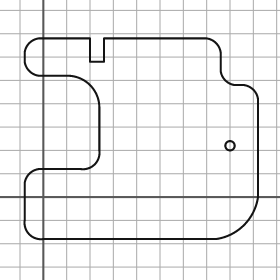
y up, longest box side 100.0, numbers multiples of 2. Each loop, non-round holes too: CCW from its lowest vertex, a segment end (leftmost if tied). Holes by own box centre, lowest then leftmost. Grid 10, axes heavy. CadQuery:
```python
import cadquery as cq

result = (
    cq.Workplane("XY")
    .moveTo(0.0, -18.0)
    .lineTo(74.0, -18.0)
    .threePointArc((86.0, -12.0), (92.0, 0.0))
    .lineTo(92.0, 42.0)
    .threePointArc((90.0, 46.0), (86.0, 48.0))
    .lineTo(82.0, 48.0)
    .threePointArc((78.0, 50.0), (76.0, 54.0))
    .lineTo(76.0, 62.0)
    .threePointArc((74.0, 66.0), (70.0, 68.0))
    .lineTo(26.0, 68.0)
    .lineTo(26.0, 58.0)
    .lineTo(20.0, 58.0)
    .lineTo(20.0, 68.0)
    .lineTo(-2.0, 68.0)
    .threePointArc((-6.0, 66.0), (-8.0, 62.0))
    .lineTo(-8.0, 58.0)
    .threePointArc((-6.0, 54.0), (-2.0, 52.0))
    .lineTo(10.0, 52.0)
    .threePointArc((20.0, 48.0), (24.0, 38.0))
    .lineTo(24.0, 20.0)
    .threePointArc((22.0, 14.0), (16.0, 12.0))
    .lineTo(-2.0, 12.0)
    .threePointArc((-6.0, 10.0), (-8.0, 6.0))
    .lineTo(-8.0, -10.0)
    .threePointArc((-6.0, -16.0), (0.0, -18.0))
    .close()
    .moveTo(80.0, 22.0)
    .circle(2.0)
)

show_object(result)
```